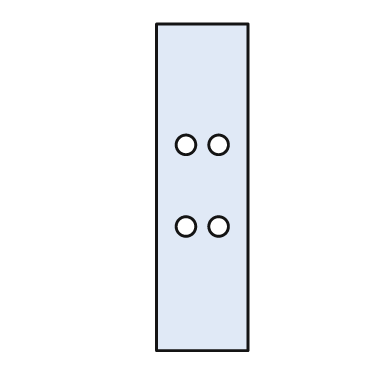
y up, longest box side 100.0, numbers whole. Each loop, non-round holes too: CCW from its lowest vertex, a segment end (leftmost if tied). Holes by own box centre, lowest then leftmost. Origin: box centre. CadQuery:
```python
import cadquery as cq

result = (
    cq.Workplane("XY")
    .moveTo(-14.0, -50.0)
    .lineTo(14.0, -50.0)
    .lineTo(14.0, 50.0)
    .lineTo(-14.0, 50.0)
    .close()
    .moveTo(-5.0, -12.0)
    .circle(3.0)
    .moveTo(5.0, -12.0)
    .circle(3.0)
    .moveTo(-5.0, 13.0)
    .circle(3.0)
    .moveTo(5.0, 13.0)
    .circle(3.0)
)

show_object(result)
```